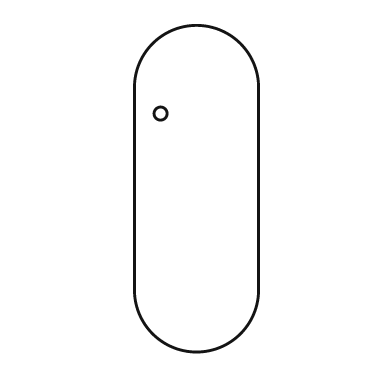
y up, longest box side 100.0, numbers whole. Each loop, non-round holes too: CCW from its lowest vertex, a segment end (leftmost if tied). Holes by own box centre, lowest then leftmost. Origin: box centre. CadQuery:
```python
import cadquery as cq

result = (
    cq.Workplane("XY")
    .moveTo(-19.0, -31.0)
    .threePointArc((0.0, -50.0), (19.0, -31.0))
    .lineTo(19.0, 31.0)
    .threePointArc((0.0, 50.0), (-19.0, 31.0))
    .close()
    .moveTo(-11.0, 23.0)
    .circle(2.0)
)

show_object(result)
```